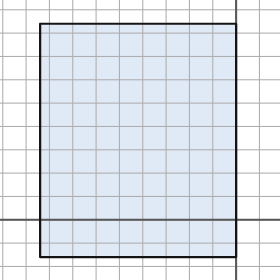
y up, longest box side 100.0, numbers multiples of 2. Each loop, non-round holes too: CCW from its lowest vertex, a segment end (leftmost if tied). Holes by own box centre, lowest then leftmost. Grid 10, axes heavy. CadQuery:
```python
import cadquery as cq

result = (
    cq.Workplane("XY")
    .moveTo(-84.0, -16.0)
    .lineTo(0.0, -16.0)
    .lineTo(0.0, 84.0)
    .lineTo(-84.0, 84.0)
    .close()
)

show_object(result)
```